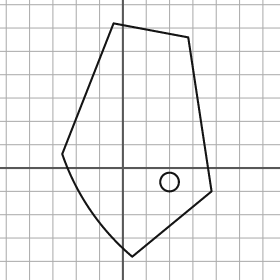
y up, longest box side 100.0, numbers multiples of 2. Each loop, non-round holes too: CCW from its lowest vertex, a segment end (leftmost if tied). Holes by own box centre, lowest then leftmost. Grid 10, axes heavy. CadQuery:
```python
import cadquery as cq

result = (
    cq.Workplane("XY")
    .moveTo(4.0, -38.0)
    .lineTo(38.0, -10.0)
    .lineTo(28.0, 56.0)
    .lineTo(-4.0, 62.0)
    .lineTo(-26.0, 6.0)
    .threePointArc((-14.0, -18.0), (4.0, -38.0))
    .close()
    .moveTo(20.0, -6.0)
    .circle(4.0)
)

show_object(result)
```